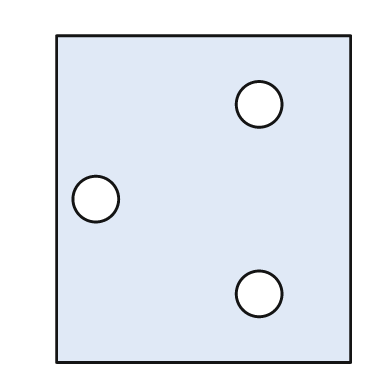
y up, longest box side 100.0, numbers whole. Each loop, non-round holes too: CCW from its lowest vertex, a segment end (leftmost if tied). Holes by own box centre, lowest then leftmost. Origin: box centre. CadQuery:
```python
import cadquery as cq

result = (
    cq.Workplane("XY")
    .moveTo(-45.0, -50.0)
    .lineTo(45.0, -50.0)
    .lineTo(45.0, 50.0)
    .lineTo(-45.0, 50.0)
    .close()
    .moveTo(17.0, -29.0)
    .circle(7.0)
    .moveTo(-33.0, 0.0)
    .circle(7.0)
    .moveTo(17.0, 29.0)
    .circle(7.0)
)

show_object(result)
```